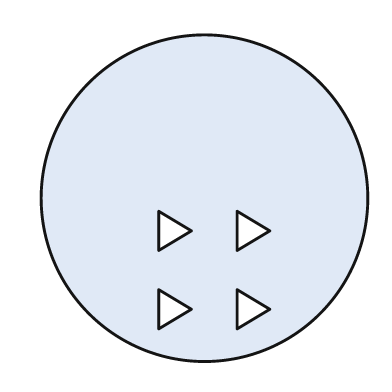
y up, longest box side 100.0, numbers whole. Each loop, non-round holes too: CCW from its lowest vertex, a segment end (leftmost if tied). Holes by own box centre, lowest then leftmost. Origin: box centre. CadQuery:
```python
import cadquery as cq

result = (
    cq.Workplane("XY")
    .moveTo(0.0, 0.0)
    .circle(50.0)
    .moveTo(-14.0, -40.0)
    .lineTo(-4.0, -34.0)
    .lineTo(-14.0, -28.0)
    .close()
    .moveTo(10.0, -40.0)
    .lineTo(20.0, -34.0)
    .lineTo(10.0, -28.0)
    .close()
    .moveTo(-14.0, -16.0)
    .lineTo(-4.0, -10.0)
    .lineTo(-14.0, -4.0)
    .close()
    .moveTo(10.0, -16.0)
    .lineTo(20.0, -10.0)
    .lineTo(10.0, -4.0)
    .close()
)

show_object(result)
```